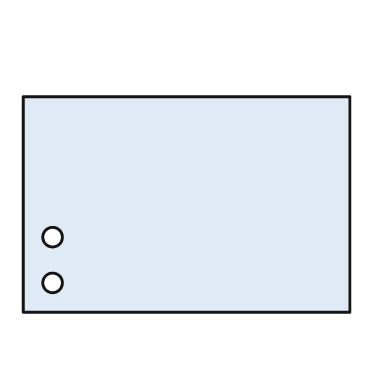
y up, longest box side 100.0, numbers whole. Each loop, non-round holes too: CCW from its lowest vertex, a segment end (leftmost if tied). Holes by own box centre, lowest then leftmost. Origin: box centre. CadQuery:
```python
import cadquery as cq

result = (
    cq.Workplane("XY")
    .moveTo(-50.0, -33.0)
    .lineTo(50.0, -33.0)
    .lineTo(50.0, 33.0)
    .lineTo(-50.0, 33.0)
    .close()
    .moveTo(-41.0, -24.0)
    .circle(3.0)
    .moveTo(-41.0, -10.0)
    .circle(3.0)
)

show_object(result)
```